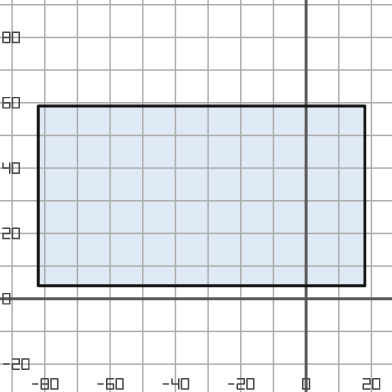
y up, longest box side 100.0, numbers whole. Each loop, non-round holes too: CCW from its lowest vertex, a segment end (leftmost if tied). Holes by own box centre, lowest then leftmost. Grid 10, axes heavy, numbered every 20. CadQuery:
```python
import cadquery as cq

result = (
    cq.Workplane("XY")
    .moveTo(-82.0, 4.0)
    .lineTo(18.0, 4.0)
    .lineTo(18.0, 59.0)
    .lineTo(-82.0, 59.0)
    .close()
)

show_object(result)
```